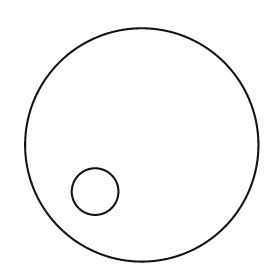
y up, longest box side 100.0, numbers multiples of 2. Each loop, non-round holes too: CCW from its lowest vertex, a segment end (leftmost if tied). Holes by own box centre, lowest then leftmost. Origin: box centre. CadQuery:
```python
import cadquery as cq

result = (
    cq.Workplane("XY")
    .moveTo(0.0, 0.0)
    .circle(50.0)
    .moveTo(-20.0, -20.0)
    .circle(10.0)
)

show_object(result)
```